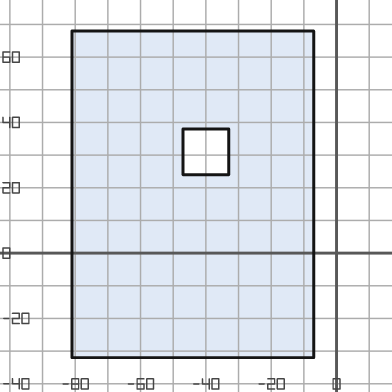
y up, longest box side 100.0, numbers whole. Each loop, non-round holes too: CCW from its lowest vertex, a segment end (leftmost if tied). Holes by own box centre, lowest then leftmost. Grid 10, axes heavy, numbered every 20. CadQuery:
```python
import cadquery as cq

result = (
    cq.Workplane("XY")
    .moveTo(-81.0, -32.0)
    .lineTo(-7.0, -32.0)
    .lineTo(-7.0, 68.0)
    .lineTo(-81.0, 68.0)
    .close()
    .moveTo(-47.0, 24.0)
    .lineTo(-33.0, 24.0)
    .lineTo(-33.0, 38.0)
    .lineTo(-47.0, 38.0)
    .close()
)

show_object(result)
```